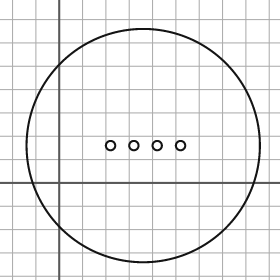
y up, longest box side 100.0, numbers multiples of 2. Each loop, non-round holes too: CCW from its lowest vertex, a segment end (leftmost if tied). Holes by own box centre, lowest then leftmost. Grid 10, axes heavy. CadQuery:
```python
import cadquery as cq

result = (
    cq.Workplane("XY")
    .moveTo(36.0, 16.0)
    .circle(50.0)
    .moveTo(22.0, 16.0)
    .circle(2.0)
    .moveTo(32.0, 16.0)
    .circle(2.0)
    .moveTo(42.0, 16.0)
    .circle(2.0)
    .moveTo(52.0, 16.0)
    .circle(2.0)
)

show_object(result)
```